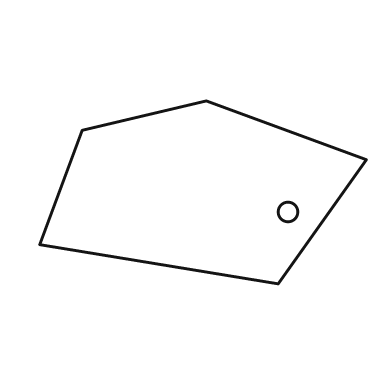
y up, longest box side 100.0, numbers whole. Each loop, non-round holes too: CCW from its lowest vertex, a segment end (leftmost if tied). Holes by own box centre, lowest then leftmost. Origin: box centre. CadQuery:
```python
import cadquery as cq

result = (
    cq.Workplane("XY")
    .moveTo(23.0, -28.0)
    .lineTo(50.0, 10.0)
    .lineTo(1.0, 28.0)
    .lineTo(-37.0, 19.0)
    .lineTo(-50.0, -16.0)
    .close()
    .moveTo(26.0, -6.0)
    .circle(3.0)
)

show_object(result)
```